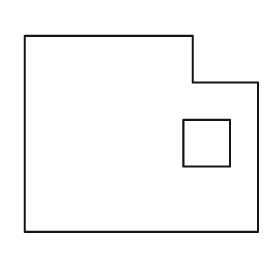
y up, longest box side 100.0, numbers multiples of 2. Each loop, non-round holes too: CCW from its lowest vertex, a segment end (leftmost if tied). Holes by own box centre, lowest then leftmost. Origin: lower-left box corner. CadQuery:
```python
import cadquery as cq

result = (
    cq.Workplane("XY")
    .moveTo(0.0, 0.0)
    .lineTo(100.0, 0.0)
    .lineTo(100.0, 64.0)
    .lineTo(72.0, 64.0)
    .lineTo(72.0, 84.0)
    .lineTo(0.0, 84.0)
    .close()
    .moveTo(68.0, 28.0)
    .lineTo(88.0, 28.0)
    .lineTo(88.0, 48.0)
    .lineTo(68.0, 48.0)
    .close()
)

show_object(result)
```